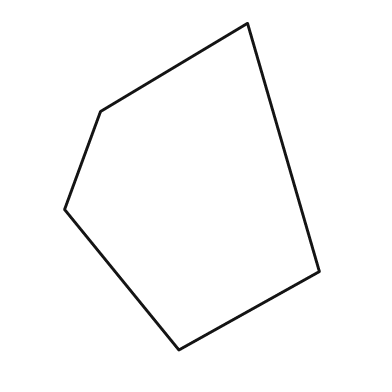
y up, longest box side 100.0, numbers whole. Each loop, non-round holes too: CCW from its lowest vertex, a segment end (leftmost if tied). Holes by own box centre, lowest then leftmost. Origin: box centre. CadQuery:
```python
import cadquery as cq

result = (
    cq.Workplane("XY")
    .moveTo(-4.0, -50.0)
    .lineTo(39.0, -26.0)
    .lineTo(17.0, 50.0)
    .lineTo(-28.0, 23.0)
    .lineTo(-39.0, -7.0)
    .close()
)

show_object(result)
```